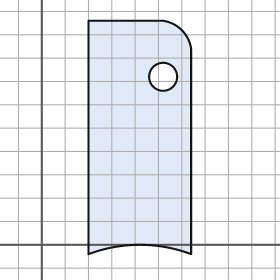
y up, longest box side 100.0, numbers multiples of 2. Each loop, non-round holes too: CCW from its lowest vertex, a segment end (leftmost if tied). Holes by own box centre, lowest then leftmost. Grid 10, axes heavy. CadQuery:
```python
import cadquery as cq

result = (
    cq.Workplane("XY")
    .moveTo(20.0, -4.0)
    .threePointArc((42.0, 0.0), (64.0, -4.0))
    .lineTo(64.0, 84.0)
    .threePointArc((60.0, 92.0), (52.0, 96.0))
    .lineTo(20.0, 96.0)
    .close()
    .moveTo(52.0, 72.0)
    .circle(6.0)
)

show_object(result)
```